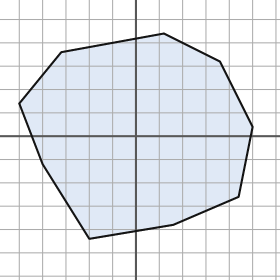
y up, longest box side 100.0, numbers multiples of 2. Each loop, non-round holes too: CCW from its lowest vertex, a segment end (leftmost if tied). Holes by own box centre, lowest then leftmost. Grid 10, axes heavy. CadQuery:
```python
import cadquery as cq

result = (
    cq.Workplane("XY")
    .moveTo(-20.0, -44.0)
    .lineTo(16.0, -38.0)
    .lineTo(44.0, -26.0)
    .lineTo(50.0, 4.0)
    .lineTo(36.0, 32.0)
    .lineTo(12.0, 44.0)
    .lineTo(-32.0, 36.0)
    .lineTo(-50.0, 14.0)
    .lineTo(-40.0, -12.0)
    .close()
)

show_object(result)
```